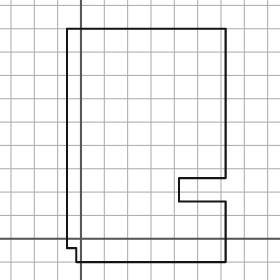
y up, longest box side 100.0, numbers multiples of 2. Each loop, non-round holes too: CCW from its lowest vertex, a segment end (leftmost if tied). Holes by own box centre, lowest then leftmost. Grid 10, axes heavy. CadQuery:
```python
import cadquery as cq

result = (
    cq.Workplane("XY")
    .moveTo(-2.0, -10.0)
    .lineTo(62.0, -10.0)
    .lineTo(62.0, 16.0)
    .lineTo(42.0, 16.0)
    .lineTo(42.0, 26.0)
    .lineTo(62.0, 26.0)
    .lineTo(62.0, 90.0)
    .lineTo(-6.0, 90.0)
    .lineTo(-6.0, -4.0)
    .lineTo(-2.0, -4.0)
    .close()
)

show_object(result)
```